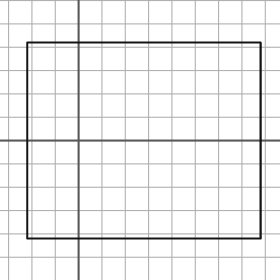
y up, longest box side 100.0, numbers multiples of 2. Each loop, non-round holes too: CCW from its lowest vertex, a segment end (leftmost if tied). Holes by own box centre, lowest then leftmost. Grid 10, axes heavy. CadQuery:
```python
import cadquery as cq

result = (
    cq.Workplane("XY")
    .moveTo(-22.0, -42.0)
    .lineTo(78.0, -42.0)
    .lineTo(78.0, 42.0)
    .lineTo(-22.0, 42.0)
    .close()
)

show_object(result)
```